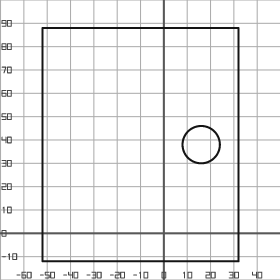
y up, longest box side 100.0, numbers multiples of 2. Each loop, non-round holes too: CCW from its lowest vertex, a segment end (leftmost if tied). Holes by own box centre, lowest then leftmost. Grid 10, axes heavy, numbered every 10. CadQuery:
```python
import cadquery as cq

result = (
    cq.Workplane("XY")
    .moveTo(-52.0, -12.0)
    .lineTo(32.0, -12.0)
    .lineTo(32.0, 88.0)
    .lineTo(-52.0, 88.0)
    .close()
    .moveTo(16.0, 38.0)
    .circle(8.0)
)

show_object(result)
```